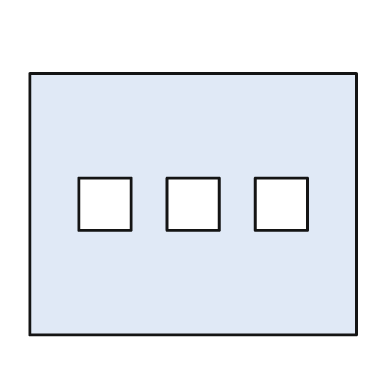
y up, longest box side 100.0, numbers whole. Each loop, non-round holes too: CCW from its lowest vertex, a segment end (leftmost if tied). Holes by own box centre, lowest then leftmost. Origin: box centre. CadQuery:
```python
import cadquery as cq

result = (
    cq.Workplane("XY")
    .moveTo(-50.0, -40.0)
    .lineTo(50.0, -40.0)
    .lineTo(50.0, 40.0)
    .lineTo(-50.0, 40.0)
    .close()
    .moveTo(-35.0, -8.0)
    .lineTo(-19.0, -8.0)
    .lineTo(-19.0, 8.0)
    .lineTo(-35.0, 8.0)
    .close()
    .moveTo(-8.0, -8.0)
    .lineTo(8.0, -8.0)
    .lineTo(8.0, 8.0)
    .lineTo(-8.0, 8.0)
    .close()
    .moveTo(19.0, -8.0)
    .lineTo(35.0, -8.0)
    .lineTo(35.0, 8.0)
    .lineTo(19.0, 8.0)
    .close()
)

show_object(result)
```